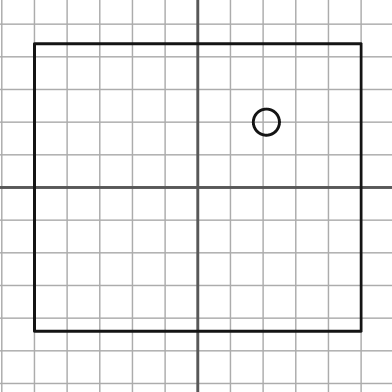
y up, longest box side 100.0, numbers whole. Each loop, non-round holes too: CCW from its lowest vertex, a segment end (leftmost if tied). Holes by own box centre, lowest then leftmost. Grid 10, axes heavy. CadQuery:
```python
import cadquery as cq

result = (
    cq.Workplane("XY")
    .moveTo(-50.0, -44.0)
    .lineTo(50.0, -44.0)
    .lineTo(50.0, 44.0)
    .lineTo(-50.0, 44.0)
    .close()
    .moveTo(21.0, 20.0)
    .circle(4.0)
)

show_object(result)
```